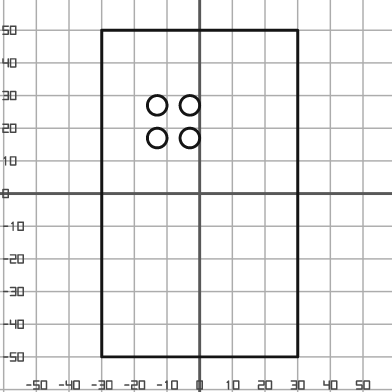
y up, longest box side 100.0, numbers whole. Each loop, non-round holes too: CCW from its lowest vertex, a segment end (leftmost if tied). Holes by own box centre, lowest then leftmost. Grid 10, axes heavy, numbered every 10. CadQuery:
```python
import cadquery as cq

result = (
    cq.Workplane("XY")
    .moveTo(-30.0, -50.0)
    .lineTo(30.0, -50.0)
    .lineTo(30.0, 50.0)
    .lineTo(-30.0, 50.0)
    .close()
    .moveTo(-13.0, 17.0)
    .circle(3.0)
    .moveTo(-3.0, 17.0)
    .circle(3.0)
    .moveTo(-13.0, 27.0)
    .circle(3.0)
    .moveTo(-3.0, 27.0)
    .circle(3.0)
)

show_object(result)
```